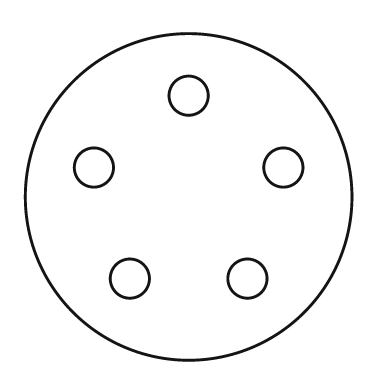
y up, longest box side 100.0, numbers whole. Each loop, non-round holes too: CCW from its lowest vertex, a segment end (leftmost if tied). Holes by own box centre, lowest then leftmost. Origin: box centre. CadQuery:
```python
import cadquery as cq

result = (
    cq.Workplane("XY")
    .moveTo(0.0, 0.0)
    .circle(50.0)
    .moveTo(-18.0, -25.0)
    .circle(6.0)
    .moveTo(18.0, -25.0)
    .circle(6.0)
    .moveTo(-29.0, 9.0)
    .circle(6.0)
    .moveTo(29.0, 9.0)
    .circle(6.0)
    .moveTo(0.0, 31.0)
    .circle(6.0)
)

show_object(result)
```